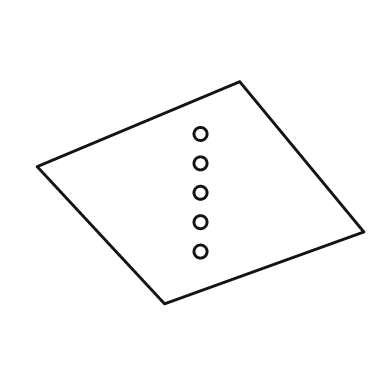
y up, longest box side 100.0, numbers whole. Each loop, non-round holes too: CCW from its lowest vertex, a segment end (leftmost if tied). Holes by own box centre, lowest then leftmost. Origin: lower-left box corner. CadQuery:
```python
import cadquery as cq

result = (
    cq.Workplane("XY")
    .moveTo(39.0, 0.0)
    .lineTo(100.0, 22.0)
    .lineTo(62.0, 68.0)
    .lineTo(0.0, 42.0)
    .close()
    .moveTo(50.0, 16.0)
    .circle(2.0)
    .moveTo(50.0, 25.0)
    .circle(2.0)
    .moveTo(50.0, 34.0)
    .circle(2.0)
    .moveTo(50.0, 43.0)
    .circle(2.0)
    .moveTo(50.0, 52.0)
    .circle(2.0)
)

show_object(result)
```